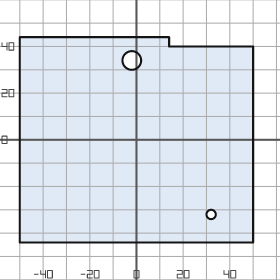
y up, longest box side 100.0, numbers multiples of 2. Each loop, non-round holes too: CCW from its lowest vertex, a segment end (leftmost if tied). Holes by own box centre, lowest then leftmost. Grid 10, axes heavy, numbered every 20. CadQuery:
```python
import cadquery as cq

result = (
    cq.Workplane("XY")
    .moveTo(-50.0, -44.0)
    .lineTo(50.0, -44.0)
    .lineTo(50.0, 40.0)
    .lineTo(14.0, 40.0)
    .lineTo(14.0, 44.0)
    .lineTo(-50.0, 44.0)
    .close()
    .moveTo(32.0, -32.0)
    .circle(2.0)
    .moveTo(-2.0, 34.0)
    .circle(4.0)
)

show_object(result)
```